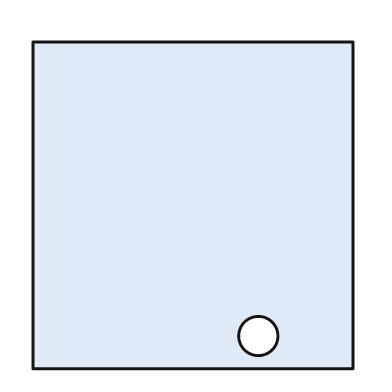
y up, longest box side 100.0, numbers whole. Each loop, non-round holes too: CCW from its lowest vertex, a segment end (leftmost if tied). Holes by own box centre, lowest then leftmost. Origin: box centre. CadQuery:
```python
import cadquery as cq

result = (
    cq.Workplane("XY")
    .moveTo(-49.0, -50.0)
    .lineTo(49.0, -50.0)
    .lineTo(49.0, 50.0)
    .lineTo(-49.0, 50.0)
    .close()
    .moveTo(20.0, -40.0)
    .circle(6.0)
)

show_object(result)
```